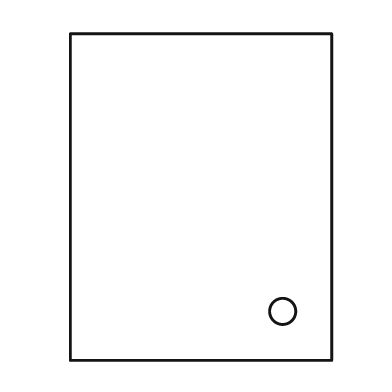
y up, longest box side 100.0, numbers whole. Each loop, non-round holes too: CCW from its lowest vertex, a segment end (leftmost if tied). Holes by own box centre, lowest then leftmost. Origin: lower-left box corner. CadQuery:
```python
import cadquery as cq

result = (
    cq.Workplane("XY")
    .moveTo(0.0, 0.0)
    .lineTo(80.0, 0.0)
    .lineTo(80.0, 100.0)
    .lineTo(0.0, 100.0)
    .close()
    .moveTo(65.0, 15.0)
    .circle(4.0)
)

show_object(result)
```